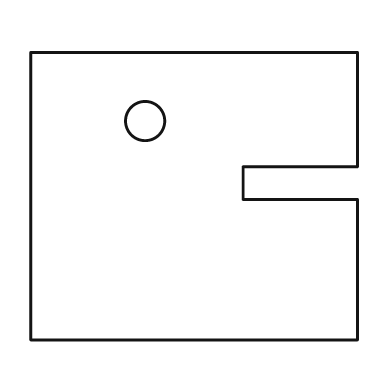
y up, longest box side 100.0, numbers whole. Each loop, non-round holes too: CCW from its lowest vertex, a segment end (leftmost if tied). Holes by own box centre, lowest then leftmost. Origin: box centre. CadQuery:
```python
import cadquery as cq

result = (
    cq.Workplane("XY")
    .moveTo(-50.0, -44.0)
    .lineTo(50.0, -44.0)
    .lineTo(50.0, -1.0)
    .lineTo(15.0, -1.0)
    .lineTo(15.0, 9.0)
    .lineTo(50.0, 9.0)
    .lineTo(50.0, 44.0)
    .lineTo(-50.0, 44.0)
    .close()
    .moveTo(-15.0, 23.0)
    .circle(6.0)
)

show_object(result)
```